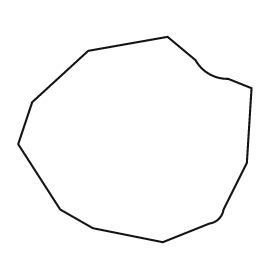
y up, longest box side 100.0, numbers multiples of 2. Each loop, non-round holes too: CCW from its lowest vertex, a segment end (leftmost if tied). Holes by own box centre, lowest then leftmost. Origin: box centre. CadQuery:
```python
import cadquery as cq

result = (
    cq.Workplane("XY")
    .moveTo(12.0, -44.0)
    .lineTo(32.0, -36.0)
    .threePointArc((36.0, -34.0), (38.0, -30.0))
    .lineTo(48.0, -10.0)
    .lineTo(50.0, 22.0)
    .lineTo(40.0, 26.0)
    .threePointArc((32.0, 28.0), (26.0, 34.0))
    .lineTo(14.0, 44.0)
    .lineTo(-20.0, 38.0)
    .lineTo(-44.0, 16.0)
    .lineTo(-50.0, -2.0)
    .lineTo(-32.0, -30.0)
    .lineTo(-18.0, -38.0)
    .close()
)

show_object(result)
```